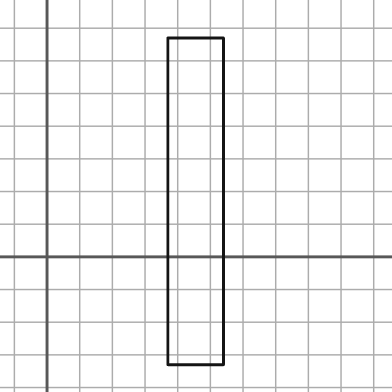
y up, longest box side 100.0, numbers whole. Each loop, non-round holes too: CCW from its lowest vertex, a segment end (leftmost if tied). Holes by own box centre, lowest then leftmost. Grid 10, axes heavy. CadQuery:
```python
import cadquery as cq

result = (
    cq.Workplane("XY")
    .moveTo(37.0, -33.0)
    .lineTo(54.0, -33.0)
    .lineTo(54.0, 67.0)
    .lineTo(37.0, 67.0)
    .close()
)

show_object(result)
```